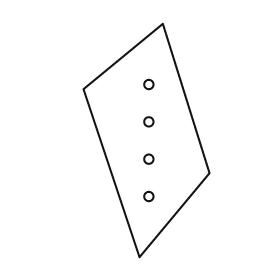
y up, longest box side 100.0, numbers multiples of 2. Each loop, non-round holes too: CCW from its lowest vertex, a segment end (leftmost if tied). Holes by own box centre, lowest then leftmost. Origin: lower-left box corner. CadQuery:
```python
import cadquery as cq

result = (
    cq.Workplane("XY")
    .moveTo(24.0, 0.0)
    .lineTo(54.0, 36.0)
    .lineTo(34.0, 100.0)
    .lineTo(0.0, 72.0)
    .close()
    .moveTo(28.0, 26.0)
    .circle(2.0)
    .moveTo(28.0, 42.0)
    .circle(2.0)
    .moveTo(28.0, 58.0)
    .circle(2.0)
    .moveTo(28.0, 74.0)
    .circle(2.0)
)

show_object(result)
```